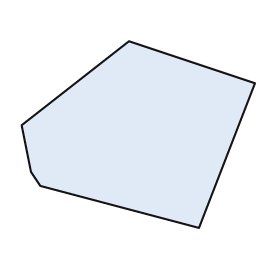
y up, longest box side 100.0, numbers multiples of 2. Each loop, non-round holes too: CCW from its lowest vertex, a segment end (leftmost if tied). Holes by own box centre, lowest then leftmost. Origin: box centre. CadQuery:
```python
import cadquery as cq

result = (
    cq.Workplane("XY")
    .moveTo(26.0, -40.0)
    .lineTo(50.0, 22.0)
    .lineTo(-4.0, 40.0)
    .lineTo(-50.0, 4.0)
    .lineTo(-46.0, -16.0)
    .lineTo(-42.0, -22.0)
    .close()
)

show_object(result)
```